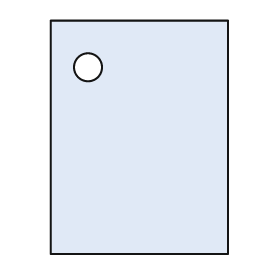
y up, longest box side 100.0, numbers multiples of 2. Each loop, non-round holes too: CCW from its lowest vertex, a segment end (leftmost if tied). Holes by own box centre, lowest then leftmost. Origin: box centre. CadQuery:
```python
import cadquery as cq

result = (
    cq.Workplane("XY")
    .moveTo(-38.0, -50.0)
    .lineTo(38.0, -50.0)
    .lineTo(38.0, 50.0)
    .lineTo(-38.0, 50.0)
    .close()
    .moveTo(-22.0, 30.0)
    .circle(6.0)
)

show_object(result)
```